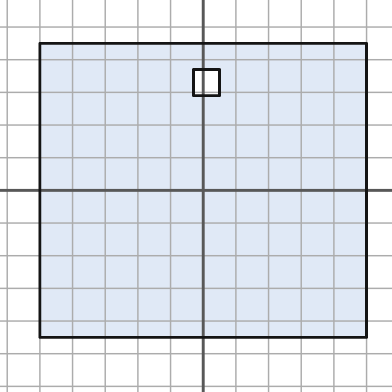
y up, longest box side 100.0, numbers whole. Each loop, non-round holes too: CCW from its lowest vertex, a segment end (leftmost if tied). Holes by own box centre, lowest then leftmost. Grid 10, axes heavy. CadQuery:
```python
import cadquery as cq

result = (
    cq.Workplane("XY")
    .moveTo(-50.0, -45.0)
    .lineTo(50.0, -45.0)
    .lineTo(50.0, 45.0)
    .lineTo(-50.0, 45.0)
    .close()
    .moveTo(-3.0, 29.0)
    .lineTo(5.0, 29.0)
    .lineTo(5.0, 37.0)
    .lineTo(-3.0, 37.0)
    .close()
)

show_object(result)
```